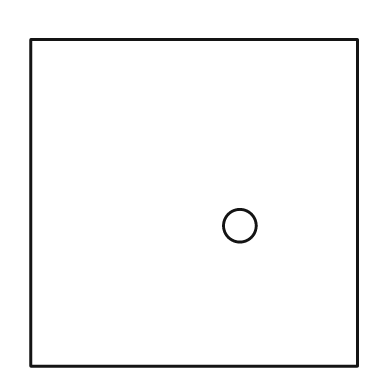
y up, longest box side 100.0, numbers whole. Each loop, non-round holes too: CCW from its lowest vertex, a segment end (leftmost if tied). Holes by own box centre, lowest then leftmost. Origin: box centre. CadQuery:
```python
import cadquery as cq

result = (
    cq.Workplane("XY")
    .moveTo(-50.0, -50.0)
    .lineTo(50.0, -50.0)
    .lineTo(50.0, 50.0)
    .lineTo(-50.0, 50.0)
    .close()
    .moveTo(14.0, -7.0)
    .circle(5.0)
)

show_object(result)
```